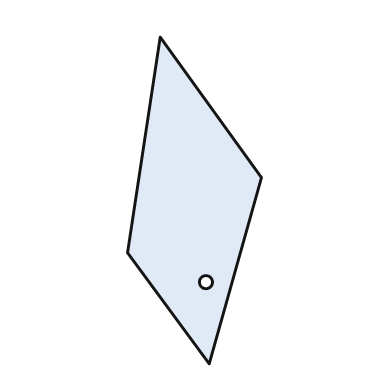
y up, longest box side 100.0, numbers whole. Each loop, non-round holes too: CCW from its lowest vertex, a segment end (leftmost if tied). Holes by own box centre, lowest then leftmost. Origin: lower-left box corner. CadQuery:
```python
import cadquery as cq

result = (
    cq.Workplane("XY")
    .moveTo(25.0, 0.0)
    .lineTo(41.0, 57.0)
    .lineTo(10.0, 100.0)
    .lineTo(0.0, 34.0)
    .close()
    .moveTo(24.0, 25.0)
    .circle(2.0)
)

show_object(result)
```